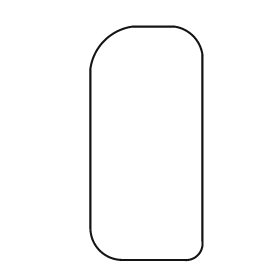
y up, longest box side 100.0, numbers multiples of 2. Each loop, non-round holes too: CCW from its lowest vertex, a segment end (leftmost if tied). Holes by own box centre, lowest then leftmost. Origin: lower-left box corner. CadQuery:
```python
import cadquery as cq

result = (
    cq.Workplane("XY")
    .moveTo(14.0, 0.0)
    .lineTo(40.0, 0.0)
    .threePointArc((46.0, 2.0), (48.0, 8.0))
    .lineTo(48.0, 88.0)
    .threePointArc((44.0, 96.0), (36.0, 100.0))
    .lineTo(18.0, 100.0)
    .threePointArc((6.0, 94.0), (0.0, 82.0))
    .lineTo(0.0, 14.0)
    .threePointArc((4.0, 4.0), (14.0, 0.0))
    .close()
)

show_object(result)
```